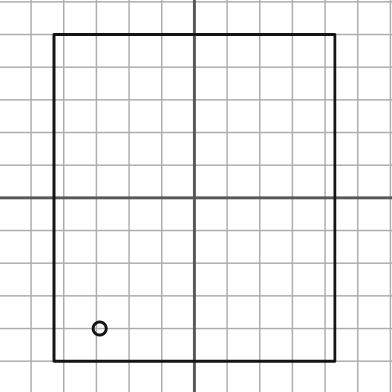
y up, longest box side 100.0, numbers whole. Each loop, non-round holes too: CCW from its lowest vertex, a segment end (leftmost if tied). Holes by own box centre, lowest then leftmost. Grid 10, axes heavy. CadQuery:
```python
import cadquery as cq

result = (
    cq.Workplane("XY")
    .moveTo(-43.0, -50.0)
    .lineTo(43.0, -50.0)
    .lineTo(43.0, 50.0)
    .lineTo(-43.0, 50.0)
    .close()
    .moveTo(-29.0, -40.0)
    .circle(2.0)
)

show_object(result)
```